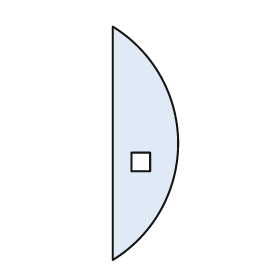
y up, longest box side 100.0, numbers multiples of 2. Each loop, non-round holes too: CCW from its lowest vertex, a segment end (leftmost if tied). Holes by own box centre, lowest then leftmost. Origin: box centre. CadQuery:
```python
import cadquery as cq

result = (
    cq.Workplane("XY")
    .moveTo(-14.0, -50.0)
    .threePointArc((14.0, 0.0), (-14.0, 50.0))
    .close()
    .moveTo(-6.0, -12.0)
    .lineTo(2.0, -12.0)
    .lineTo(2.0, -4.0)
    .lineTo(-6.0, -4.0)
    .close()
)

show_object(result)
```